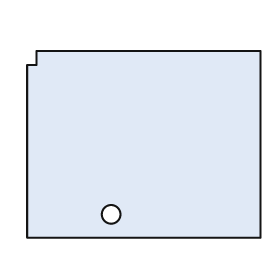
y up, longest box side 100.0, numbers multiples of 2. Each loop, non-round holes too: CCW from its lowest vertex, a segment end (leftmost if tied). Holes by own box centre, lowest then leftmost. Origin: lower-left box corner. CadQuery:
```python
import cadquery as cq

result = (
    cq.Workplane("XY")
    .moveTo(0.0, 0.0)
    .lineTo(100.0, 0.0)
    .lineTo(100.0, 80.0)
    .lineTo(4.0, 80.0)
    .lineTo(4.0, 74.0)
    .lineTo(0.0, 74.0)
    .close()
    .moveTo(36.0, 10.0)
    .circle(4.0)
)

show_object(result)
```